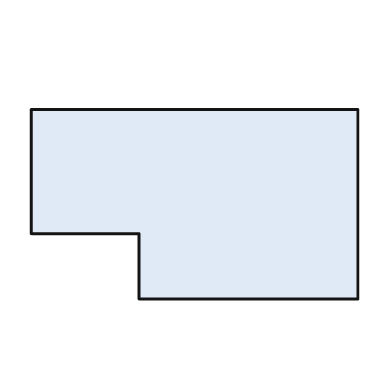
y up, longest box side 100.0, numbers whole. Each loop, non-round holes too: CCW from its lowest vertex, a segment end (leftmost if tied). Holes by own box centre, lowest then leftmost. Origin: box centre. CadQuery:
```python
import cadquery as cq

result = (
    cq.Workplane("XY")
    .moveTo(-17.0, -29.0)
    .lineTo(50.0, -29.0)
    .lineTo(50.0, 29.0)
    .lineTo(-50.0, 29.0)
    .lineTo(-50.0, -9.0)
    .lineTo(-17.0, -9.0)
    .close()
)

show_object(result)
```